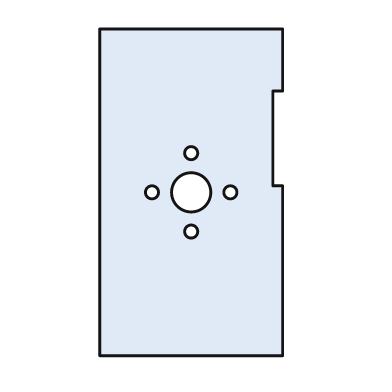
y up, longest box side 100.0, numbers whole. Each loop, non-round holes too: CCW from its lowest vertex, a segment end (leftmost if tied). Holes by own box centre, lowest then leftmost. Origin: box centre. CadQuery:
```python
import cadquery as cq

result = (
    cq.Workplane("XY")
    .moveTo(-28.0, -50.0)
    .lineTo(28.0, -50.0)
    .lineTo(28.0, 2.0)
    .lineTo(25.0, 2.0)
    .lineTo(25.0, 31.0)
    .lineTo(28.0, 31.0)
    .lineTo(28.0, 50.0)
    .lineTo(-28.0, 50.0)
    .close()
    .moveTo(0.0, -12.0)
    .circle(2.0)
    .moveTo(-12.0, 0.0)
    .circle(2.0)
    .moveTo(0.0, 0.0)
    .circle(6.0)
    .moveTo(12.0, 0.0)
    .circle(2.0)
    .moveTo(0.0, 12.0)
    .circle(2.0)
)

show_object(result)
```